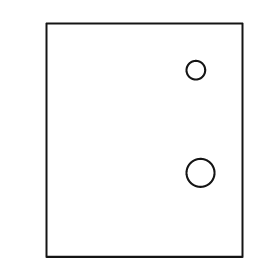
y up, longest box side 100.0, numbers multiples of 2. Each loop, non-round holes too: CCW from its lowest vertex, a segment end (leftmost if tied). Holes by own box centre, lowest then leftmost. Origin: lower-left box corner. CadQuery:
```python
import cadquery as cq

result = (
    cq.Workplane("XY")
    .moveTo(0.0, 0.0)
    .lineTo(84.0, 0.0)
    .lineTo(84.0, 100.0)
    .lineTo(0.0, 100.0)
    .close()
    .moveTo(66.0, 36.0)
    .circle(6.0)
    .moveTo(64.0, 80.0)
    .circle(4.0)
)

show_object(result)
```